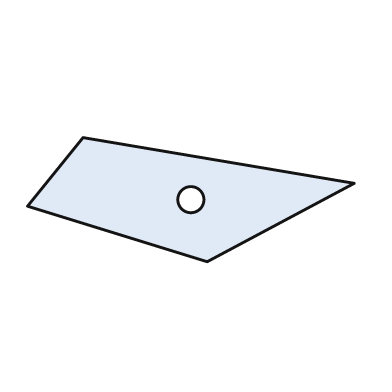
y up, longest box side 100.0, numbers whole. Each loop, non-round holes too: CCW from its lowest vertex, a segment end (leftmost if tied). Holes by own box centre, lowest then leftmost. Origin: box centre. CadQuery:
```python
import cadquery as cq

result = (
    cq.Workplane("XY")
    .moveTo(5.0, -19.0)
    .lineTo(50.0, 5.0)
    .lineTo(-33.0, 19.0)
    .lineTo(-50.0, -2.0)
    .close()
    .moveTo(0.0, 0.0)
    .circle(4.0)
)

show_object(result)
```